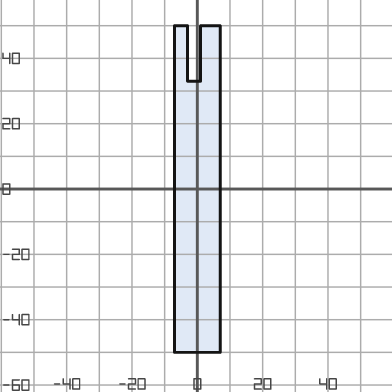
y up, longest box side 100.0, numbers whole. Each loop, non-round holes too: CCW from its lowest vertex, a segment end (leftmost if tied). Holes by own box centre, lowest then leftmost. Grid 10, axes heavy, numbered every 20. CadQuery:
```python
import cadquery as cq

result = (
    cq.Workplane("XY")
    .moveTo(-7.0, -50.0)
    .lineTo(7.0, -50.0)
    .lineTo(7.0, 50.0)
    .lineTo(1.0, 50.0)
    .lineTo(1.0, 33.0)
    .lineTo(-3.0, 33.0)
    .lineTo(-3.0, 50.0)
    .lineTo(-7.0, 50.0)
    .close()
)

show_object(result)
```